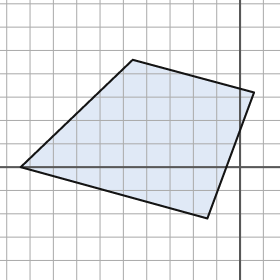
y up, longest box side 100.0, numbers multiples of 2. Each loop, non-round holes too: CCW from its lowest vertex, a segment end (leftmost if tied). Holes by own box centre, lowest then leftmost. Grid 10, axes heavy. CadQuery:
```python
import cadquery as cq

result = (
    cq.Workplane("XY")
    .moveTo(-14.0, -22.0)
    .lineTo(6.0, 32.0)
    .lineTo(-46.0, 46.0)
    .lineTo(-94.0, 0.0)
    .close()
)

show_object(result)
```